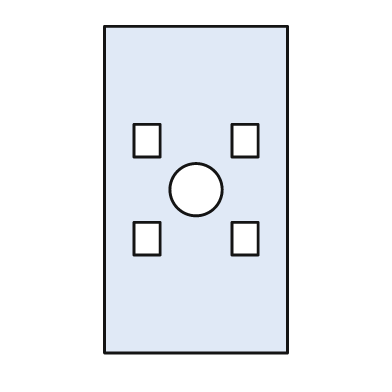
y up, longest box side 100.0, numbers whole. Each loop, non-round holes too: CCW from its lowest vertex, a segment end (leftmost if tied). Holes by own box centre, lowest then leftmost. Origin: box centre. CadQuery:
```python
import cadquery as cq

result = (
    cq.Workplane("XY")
    .moveTo(-28.0, -50.0)
    .lineTo(28.0, -50.0)
    .lineTo(28.0, 50.0)
    .lineTo(-28.0, 50.0)
    .close()
    .moveTo(-19.0, -20.0)
    .lineTo(-11.0, -20.0)
    .lineTo(-11.0, -10.0)
    .lineTo(-19.0, -10.0)
    .close()
    .moveTo(11.0, -20.0)
    .lineTo(19.0, -20.0)
    .lineTo(19.0, -10.0)
    .lineTo(11.0, -10.0)
    .close()
    .moveTo(0.0, 0.0)
    .circle(8.0)
    .moveTo(-19.0, 10.0)
    .lineTo(-11.0, 10.0)
    .lineTo(-11.0, 20.0)
    .lineTo(-19.0, 20.0)
    .close()
    .moveTo(11.0, 10.0)
    .lineTo(19.0, 10.0)
    .lineTo(19.0, 20.0)
    .lineTo(11.0, 20.0)
    .close()
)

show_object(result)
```